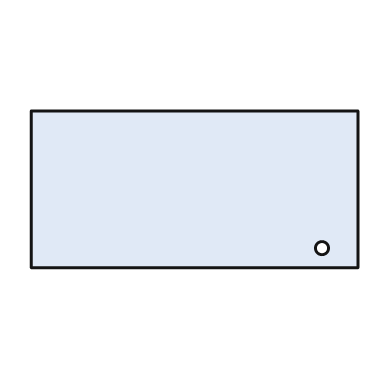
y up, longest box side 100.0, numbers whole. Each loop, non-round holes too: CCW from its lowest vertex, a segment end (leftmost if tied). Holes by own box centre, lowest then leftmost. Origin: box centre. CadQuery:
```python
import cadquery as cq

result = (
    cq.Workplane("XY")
    .moveTo(-50.0, -24.0)
    .lineTo(50.0, -24.0)
    .lineTo(50.0, 24.0)
    .lineTo(-50.0, 24.0)
    .close()
    .moveTo(39.0, -18.0)
    .circle(2.0)
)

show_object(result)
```